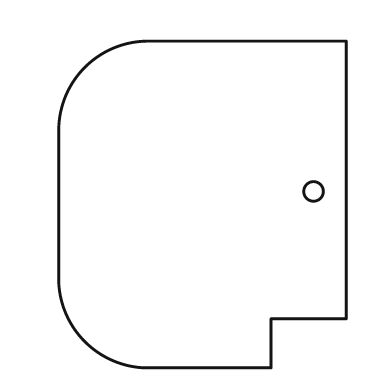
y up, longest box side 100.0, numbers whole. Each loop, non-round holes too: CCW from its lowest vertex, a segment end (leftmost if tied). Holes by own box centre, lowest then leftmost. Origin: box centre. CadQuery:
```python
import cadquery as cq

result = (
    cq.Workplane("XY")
    .moveTo(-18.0, -50.0)
    .lineTo(21.0, -50.0)
    .lineTo(21.0, -35.0)
    .lineTo(44.0, -35.0)
    .lineTo(44.0, 50.0)
    .lineTo(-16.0, 50.0)
    .threePointArc((-36.0, 42.0), (-44.0, 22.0))
    .lineTo(-44.0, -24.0)
    .threePointArc((-36.0, -42.0), (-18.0, -50.0))
    .close()
    .moveTo(34.0, 4.0)
    .circle(3.0)
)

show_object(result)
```